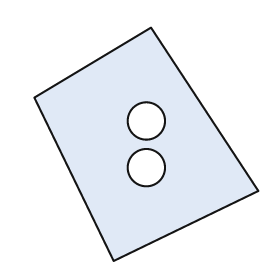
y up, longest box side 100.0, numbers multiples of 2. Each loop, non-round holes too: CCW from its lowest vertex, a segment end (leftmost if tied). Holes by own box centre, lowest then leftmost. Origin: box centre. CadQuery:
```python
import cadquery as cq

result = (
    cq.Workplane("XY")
    .moveTo(-14.0, -50.0)
    .lineTo(48.0, -20.0)
    .lineTo(2.0, 50.0)
    .lineTo(-48.0, 20.0)
    .close()
    .moveTo(0.0, -10.0)
    .circle(8.0)
    .moveTo(0.0, 10.0)
    .circle(8.0)
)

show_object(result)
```